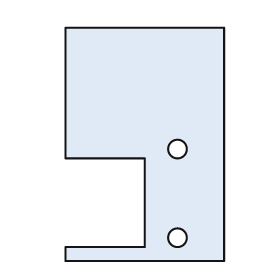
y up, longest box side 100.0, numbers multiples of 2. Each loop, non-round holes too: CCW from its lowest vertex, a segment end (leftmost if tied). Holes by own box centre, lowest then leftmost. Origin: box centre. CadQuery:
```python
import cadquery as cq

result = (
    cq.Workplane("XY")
    .moveTo(-34.0, -50.0)
    .lineTo(34.0, -50.0)
    .lineTo(34.0, 50.0)
    .lineTo(-34.0, 50.0)
    .lineTo(-34.0, -6.0)
    .lineTo(0.0, -6.0)
    .lineTo(0.0, -44.0)
    .lineTo(-34.0, -44.0)
    .close()
    .moveTo(14.0, -40.0)
    .circle(4.0)
    .moveTo(14.0, -2.0)
    .circle(4.0)
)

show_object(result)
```